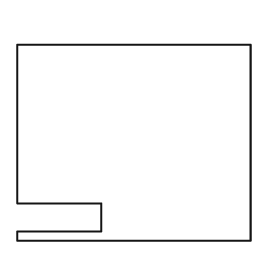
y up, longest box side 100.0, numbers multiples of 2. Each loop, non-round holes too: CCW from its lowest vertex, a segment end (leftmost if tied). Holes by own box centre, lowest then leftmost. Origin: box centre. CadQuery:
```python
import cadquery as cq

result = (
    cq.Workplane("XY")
    .moveTo(-50.0, -42.0)
    .lineTo(50.0, -42.0)
    .lineTo(50.0, 42.0)
    .lineTo(-50.0, 42.0)
    .lineTo(-50.0, -26.0)
    .lineTo(-14.0, -26.0)
    .lineTo(-14.0, -38.0)
    .lineTo(-50.0, -38.0)
    .close()
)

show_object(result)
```